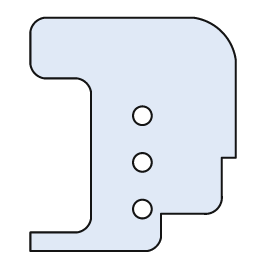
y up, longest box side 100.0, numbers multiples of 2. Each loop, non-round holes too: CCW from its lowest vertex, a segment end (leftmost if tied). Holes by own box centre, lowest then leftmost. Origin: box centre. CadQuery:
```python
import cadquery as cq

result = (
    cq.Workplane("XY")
    .moveTo(-44.0, -50.0)
    .lineTo(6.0, -50.0)
    .threePointArc((10.0, -48.0), (12.0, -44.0))
    .lineTo(12.0, -34.0)
    .lineTo(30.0, -34.0)
    .threePointArc((36.0, -32.0), (38.0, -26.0))
    .lineTo(38.0, -10.0)
    .lineTo(44.0, -10.0)
    .lineTo(44.0, 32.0)
    .threePointArc((38.0, 44.0), (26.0, 50.0))
    .lineTo(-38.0, 50.0)
    .threePointArc((-42.0, 48.0), (-44.0, 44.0))
    .lineTo(-44.0, 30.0)
    .threePointArc((-42.0, 26.0), (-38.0, 24.0))
    .lineTo(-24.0, 24.0)
    .threePointArc((-20.0, 22.0), (-18.0, 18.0))
    .lineTo(-18.0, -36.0)
    .threePointArc((-20.0, -40.0), (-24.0, -42.0))
    .lineTo(-44.0, -42.0)
    .close()
    .moveTo(4.0, -32.0)
    .circle(4.0)
    .moveTo(4.0, -12.0)
    .circle(4.0)
    .moveTo(4.0, 8.0)
    .circle(4.0)
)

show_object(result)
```